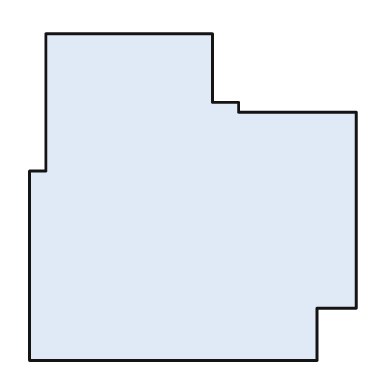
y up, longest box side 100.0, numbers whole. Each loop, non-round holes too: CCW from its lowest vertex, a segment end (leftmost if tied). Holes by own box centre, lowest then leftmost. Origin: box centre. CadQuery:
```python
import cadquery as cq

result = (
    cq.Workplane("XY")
    .moveTo(-50.0, -50.0)
    .lineTo(38.0, -50.0)
    .lineTo(38.0, -34.0)
    .lineTo(50.0, -34.0)
    .lineTo(50.0, 26.0)
    .lineTo(14.0, 26.0)
    .lineTo(14.0, 29.0)
    .lineTo(6.0, 29.0)
    .lineTo(6.0, 50.0)
    .lineTo(-45.0, 50.0)
    .lineTo(-45.0, 8.0)
    .lineTo(-50.0, 8.0)
    .close()
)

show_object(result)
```